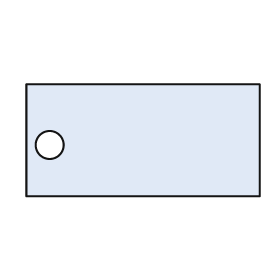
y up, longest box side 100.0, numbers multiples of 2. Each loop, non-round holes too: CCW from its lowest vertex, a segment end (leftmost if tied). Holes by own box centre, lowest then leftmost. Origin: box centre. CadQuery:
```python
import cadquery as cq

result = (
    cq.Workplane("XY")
    .moveTo(-50.0, -24.0)
    .lineTo(50.0, -24.0)
    .lineTo(50.0, 24.0)
    .lineTo(-50.0, 24.0)
    .close()
    .moveTo(-40.0, -2.0)
    .circle(6.0)
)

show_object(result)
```